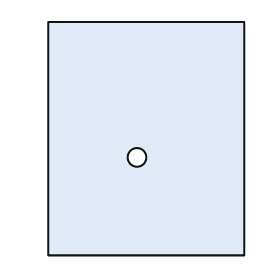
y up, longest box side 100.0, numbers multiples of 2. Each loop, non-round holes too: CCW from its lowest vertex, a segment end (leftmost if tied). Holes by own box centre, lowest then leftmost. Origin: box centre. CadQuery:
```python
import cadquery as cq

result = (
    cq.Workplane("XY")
    .moveTo(-42.0, -50.0)
    .lineTo(42.0, -50.0)
    .lineTo(42.0, 50.0)
    .lineTo(-42.0, 50.0)
    .close()
    .moveTo(-4.0, -8.0)
    .circle(4.0)
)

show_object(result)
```